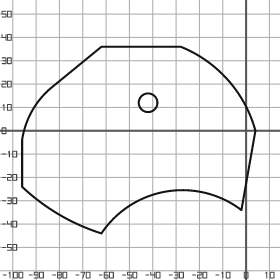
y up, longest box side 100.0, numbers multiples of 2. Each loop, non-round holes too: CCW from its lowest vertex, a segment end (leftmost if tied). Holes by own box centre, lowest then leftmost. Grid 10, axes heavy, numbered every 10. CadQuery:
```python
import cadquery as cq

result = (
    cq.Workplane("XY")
    .moveTo(-62.0, -44.0)
    .threePointArc((-34.0, -26.0), (-2.0, -34.0))
    .lineTo(4.0, 0.0)
    .threePointArc((-8.0, 22.0), (-28.0, 36.0))
    .lineTo(-62.0, 36.0)
    .lineTo(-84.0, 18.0)
    .threePointArc((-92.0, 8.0), (-96.0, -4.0))
    .lineTo(-96.0, -24.0)
    .threePointArc((-80.0, -36.0), (-62.0, -44.0))
    .close()
    .moveTo(-42.0, 12.0)
    .circle(4.0)
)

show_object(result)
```